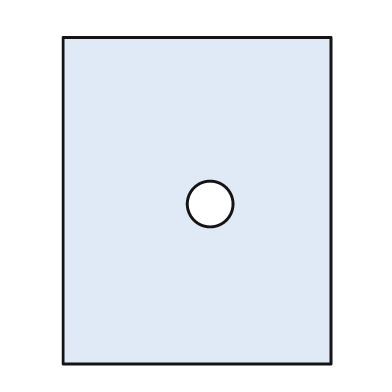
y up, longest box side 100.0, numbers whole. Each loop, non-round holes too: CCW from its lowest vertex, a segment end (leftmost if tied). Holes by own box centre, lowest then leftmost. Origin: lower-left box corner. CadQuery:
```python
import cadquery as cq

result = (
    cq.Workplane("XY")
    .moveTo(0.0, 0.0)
    .lineTo(82.0, 0.0)
    .lineTo(82.0, 100.0)
    .lineTo(0.0, 100.0)
    .close()
    .moveTo(45.0, 49.0)
    .circle(7.0)
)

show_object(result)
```